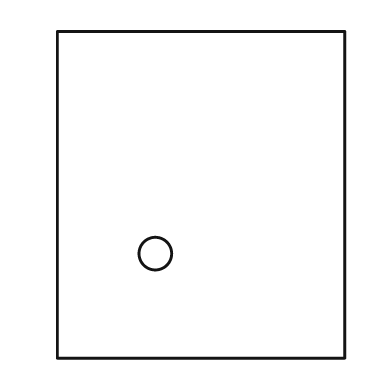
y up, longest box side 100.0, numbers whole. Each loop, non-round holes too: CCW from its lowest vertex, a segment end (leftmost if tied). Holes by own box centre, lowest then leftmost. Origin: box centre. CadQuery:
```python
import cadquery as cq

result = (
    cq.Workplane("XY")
    .moveTo(-44.0, -50.0)
    .lineTo(44.0, -50.0)
    .lineTo(44.0, 50.0)
    .lineTo(-44.0, 50.0)
    .close()
    .moveTo(-14.0, -18.0)
    .circle(5.0)
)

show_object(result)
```